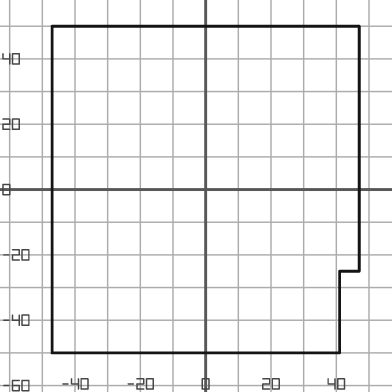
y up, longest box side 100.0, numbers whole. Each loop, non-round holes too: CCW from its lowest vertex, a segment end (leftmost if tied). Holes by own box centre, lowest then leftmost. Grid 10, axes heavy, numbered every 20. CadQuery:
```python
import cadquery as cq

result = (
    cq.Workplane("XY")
    .moveTo(-47.0, -50.0)
    .lineTo(41.0, -50.0)
    .lineTo(41.0, -25.0)
    .lineTo(47.0, -25.0)
    .lineTo(47.0, 50.0)
    .lineTo(-47.0, 50.0)
    .close()
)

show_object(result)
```